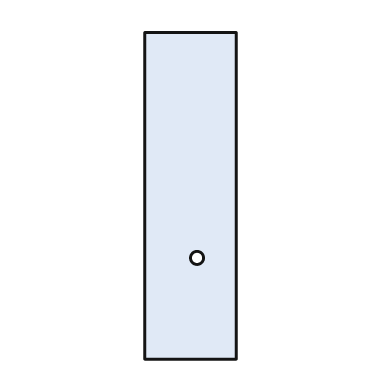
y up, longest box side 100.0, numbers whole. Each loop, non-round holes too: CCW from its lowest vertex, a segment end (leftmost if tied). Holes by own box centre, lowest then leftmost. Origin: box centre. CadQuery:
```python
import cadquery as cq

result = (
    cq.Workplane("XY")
    .moveTo(-14.0, -50.0)
    .lineTo(14.0, -50.0)
    .lineTo(14.0, 50.0)
    .lineTo(-14.0, 50.0)
    .close()
    .moveTo(2.0, -19.0)
    .circle(2.0)
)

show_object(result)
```